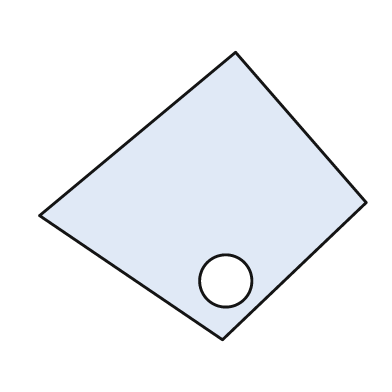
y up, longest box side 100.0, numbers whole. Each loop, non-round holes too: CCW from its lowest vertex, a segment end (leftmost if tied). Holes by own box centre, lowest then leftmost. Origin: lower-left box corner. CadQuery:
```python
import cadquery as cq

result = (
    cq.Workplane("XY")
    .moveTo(56.0, 0.0)
    .lineTo(100.0, 42.0)
    .lineTo(60.0, 88.0)
    .lineTo(0.0, 38.0)
    .close()
    .moveTo(57.0, 18.0)
    .circle(8.0)
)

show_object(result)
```